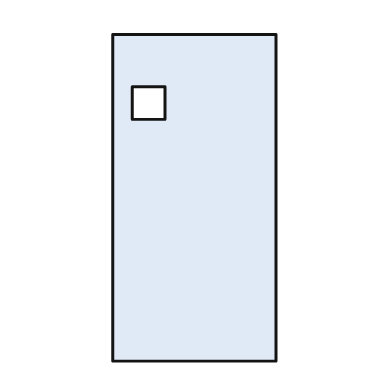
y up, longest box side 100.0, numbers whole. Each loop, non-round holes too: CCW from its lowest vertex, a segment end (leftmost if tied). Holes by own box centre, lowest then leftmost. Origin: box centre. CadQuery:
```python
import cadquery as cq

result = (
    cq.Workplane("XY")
    .moveTo(-25.0, -50.0)
    .lineTo(25.0, -50.0)
    .lineTo(25.0, 50.0)
    .lineTo(-25.0, 50.0)
    .close()
    .moveTo(-19.0, 24.0)
    .lineTo(-9.0, 24.0)
    .lineTo(-9.0, 34.0)
    .lineTo(-19.0, 34.0)
    .close()
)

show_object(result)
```